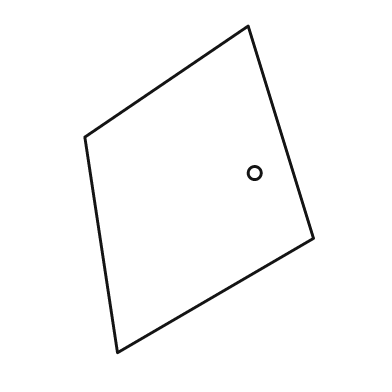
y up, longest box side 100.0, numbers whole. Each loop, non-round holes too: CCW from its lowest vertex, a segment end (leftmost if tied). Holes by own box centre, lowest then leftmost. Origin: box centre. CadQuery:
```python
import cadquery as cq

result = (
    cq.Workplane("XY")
    .moveTo(-25.0, -50.0)
    .lineTo(35.0, -15.0)
    .lineTo(15.0, 50.0)
    .lineTo(-35.0, 16.0)
    .close()
    .moveTo(17.0, 5.0)
    .circle(2.0)
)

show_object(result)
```